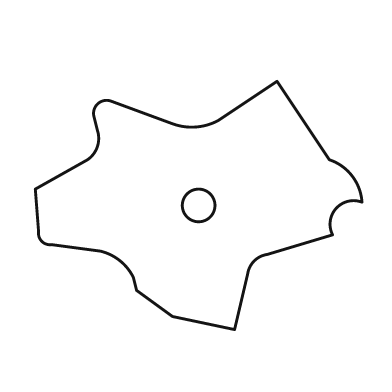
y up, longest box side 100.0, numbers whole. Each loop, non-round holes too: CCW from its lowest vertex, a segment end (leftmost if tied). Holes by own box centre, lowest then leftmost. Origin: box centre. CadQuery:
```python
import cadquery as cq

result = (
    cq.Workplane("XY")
    .moveTo(11.0, -38.0)
    .lineTo(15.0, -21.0)
    .threePointArc((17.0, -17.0), (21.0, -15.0))
    .lineTo(41.0, -9.0)
    .threePointArc((42.0, -1.0), (50.0, 1.0))
    .threePointArc((47.0, 9.0), (40.0, 14.0))
    .lineTo(24.0, 38.0)
    .lineTo(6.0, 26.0)
    .threePointArc((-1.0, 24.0), (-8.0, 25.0))
    .lineTo(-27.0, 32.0)
    .threePointArc((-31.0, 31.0), (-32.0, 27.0))
    .lineTo(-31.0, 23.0)
    .threePointArc((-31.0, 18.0), (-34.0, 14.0))
    .lineTo(-50.0, 5.0)
    .lineTo(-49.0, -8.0)
    .threePointArc((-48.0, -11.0), (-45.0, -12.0))
    .lineTo(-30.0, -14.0)
    .threePointArc((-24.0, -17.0), (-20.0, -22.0))
    .lineTo(-19.0, -26.0)
    .lineTo(-8.0, -34.0)
    .close()
    .moveTo(0.0, 0.0)
    .circle(5.0)
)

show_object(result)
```